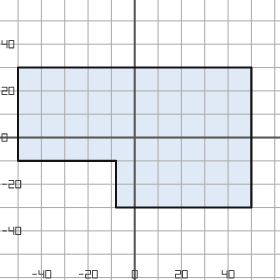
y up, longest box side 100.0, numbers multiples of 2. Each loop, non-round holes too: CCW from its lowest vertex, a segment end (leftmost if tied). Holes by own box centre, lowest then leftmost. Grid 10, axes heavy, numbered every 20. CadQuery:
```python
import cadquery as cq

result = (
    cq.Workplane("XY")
    .moveTo(-8.0, -30.0)
    .lineTo(50.0, -30.0)
    .lineTo(50.0, 30.0)
    .lineTo(-50.0, 30.0)
    .lineTo(-50.0, -10.0)
    .lineTo(-8.0, -10.0)
    .close()
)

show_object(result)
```